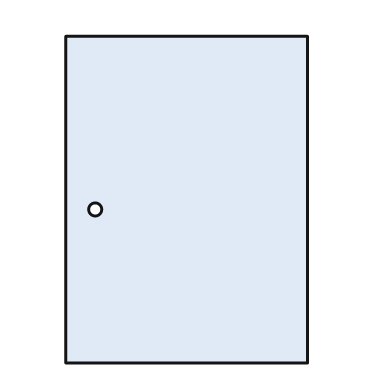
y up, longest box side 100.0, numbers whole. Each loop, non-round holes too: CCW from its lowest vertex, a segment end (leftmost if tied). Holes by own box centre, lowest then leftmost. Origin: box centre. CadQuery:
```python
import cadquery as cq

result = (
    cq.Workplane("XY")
    .moveTo(-37.0, -50.0)
    .lineTo(37.0, -50.0)
    .lineTo(37.0, 50.0)
    .lineTo(-37.0, 50.0)
    .close()
    .moveTo(-28.0, -3.0)
    .circle(2.0)
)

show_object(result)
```